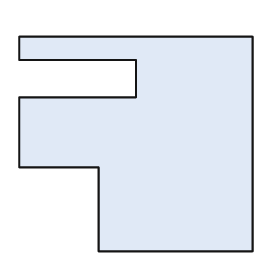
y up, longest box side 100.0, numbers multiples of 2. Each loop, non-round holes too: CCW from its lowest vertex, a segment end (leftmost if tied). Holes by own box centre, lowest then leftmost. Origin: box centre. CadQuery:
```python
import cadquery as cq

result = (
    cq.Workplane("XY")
    .moveTo(-16.0, -46.0)
    .lineTo(50.0, -46.0)
    .lineTo(50.0, 46.0)
    .lineTo(-50.0, 46.0)
    .lineTo(-50.0, 36.0)
    .lineTo(0.0, 36.0)
    .lineTo(0.0, 20.0)
    .lineTo(-50.0, 20.0)
    .lineTo(-50.0, -10.0)
    .lineTo(-16.0, -10.0)
    .close()
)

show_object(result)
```